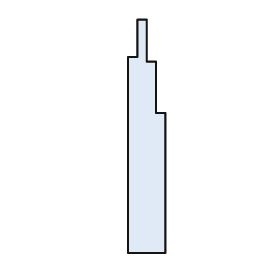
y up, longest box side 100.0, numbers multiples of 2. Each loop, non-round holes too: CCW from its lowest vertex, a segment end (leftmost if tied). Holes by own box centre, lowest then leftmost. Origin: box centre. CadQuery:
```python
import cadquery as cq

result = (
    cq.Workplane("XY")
    .moveTo(-8.0, -50.0)
    .lineTo(8.0, -50.0)
    .lineTo(8.0, 10.0)
    .lineTo(4.0, 10.0)
    .lineTo(4.0, 32.0)
    .lineTo(0.0, 32.0)
    .lineTo(0.0, 50.0)
    .lineTo(-4.0, 50.0)
    .lineTo(-4.0, 34.0)
    .lineTo(-8.0, 34.0)
    .close()
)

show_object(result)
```